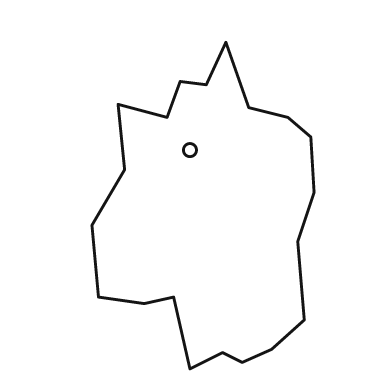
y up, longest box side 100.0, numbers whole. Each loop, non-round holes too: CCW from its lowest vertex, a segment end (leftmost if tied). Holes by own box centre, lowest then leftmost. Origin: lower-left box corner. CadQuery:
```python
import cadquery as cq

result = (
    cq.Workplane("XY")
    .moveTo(30.0, 0.0)
    .lineTo(40.0, 5.0)
    .lineTo(46.0, 2.0)
    .lineTo(55.0, 6.0)
    .lineTo(65.0, 15.0)
    .lineTo(63.0, 39.0)
    .lineTo(68.0, 54.0)
    .lineTo(67.0, 71.0)
    .lineTo(60.0, 77.0)
    .lineTo(48.0, 80.0)
    .lineTo(41.0, 100.0)
    .lineTo(35.0, 87.0)
    .lineTo(27.0, 88.0)
    .lineTo(23.0, 77.0)
    .lineTo(8.0, 81.0)
    .lineTo(10.0, 61.0)
    .lineTo(0.0, 44.0)
    .lineTo(2.0, 22.0)
    .lineTo(16.0, 20.0)
    .lineTo(25.0, 22.0)
    .close()
    .moveTo(30.0, 67.0)
    .circle(2.0)
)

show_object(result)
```